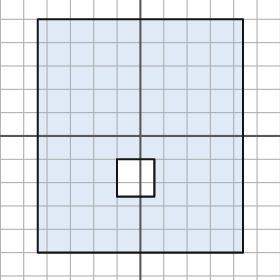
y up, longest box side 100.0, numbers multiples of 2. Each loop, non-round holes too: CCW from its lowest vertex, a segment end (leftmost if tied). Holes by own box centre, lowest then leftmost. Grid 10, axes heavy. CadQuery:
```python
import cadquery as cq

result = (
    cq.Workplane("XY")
    .moveTo(-44.0, -50.0)
    .lineTo(44.0, -50.0)
    .lineTo(44.0, 50.0)
    .lineTo(-44.0, 50.0)
    .close()
    .moveTo(-10.0, -26.0)
    .lineTo(6.0, -26.0)
    .lineTo(6.0, -10.0)
    .lineTo(-10.0, -10.0)
    .close()
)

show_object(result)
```